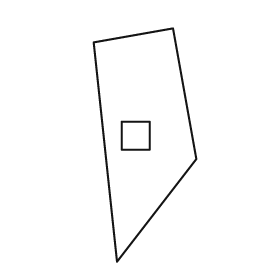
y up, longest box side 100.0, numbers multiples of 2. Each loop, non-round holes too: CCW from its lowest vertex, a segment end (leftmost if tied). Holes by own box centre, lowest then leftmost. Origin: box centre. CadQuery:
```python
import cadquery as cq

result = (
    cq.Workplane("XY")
    .moveTo(-12.0, -50.0)
    .lineTo(22.0, -6.0)
    .lineTo(12.0, 50.0)
    .lineTo(-22.0, 44.0)
    .close()
    .moveTo(-10.0, -2.0)
    .lineTo(2.0, -2.0)
    .lineTo(2.0, 10.0)
    .lineTo(-10.0, 10.0)
    .close()
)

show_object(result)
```